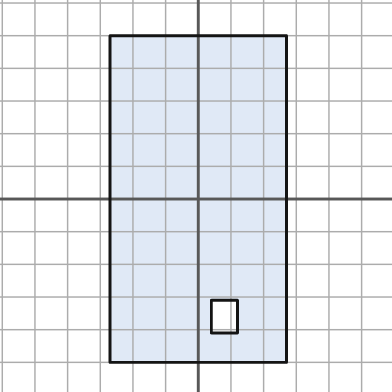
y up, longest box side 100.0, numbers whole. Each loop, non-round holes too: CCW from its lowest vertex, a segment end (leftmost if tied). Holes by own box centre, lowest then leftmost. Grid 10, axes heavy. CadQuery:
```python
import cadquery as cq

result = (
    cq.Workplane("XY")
    .moveTo(-27.0, -50.0)
    .lineTo(27.0, -50.0)
    .lineTo(27.0, 50.0)
    .lineTo(-27.0, 50.0)
    .close()
    .moveTo(4.0, -41.0)
    .lineTo(12.0, -41.0)
    .lineTo(12.0, -31.0)
    .lineTo(4.0, -31.0)
    .close()
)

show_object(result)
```